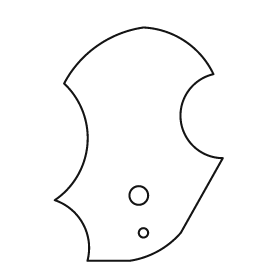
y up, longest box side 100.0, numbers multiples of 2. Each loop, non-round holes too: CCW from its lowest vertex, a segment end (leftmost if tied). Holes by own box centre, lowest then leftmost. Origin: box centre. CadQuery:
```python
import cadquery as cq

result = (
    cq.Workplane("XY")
    .moveTo(-22.0, -50.0)
    .lineTo(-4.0, -50.0)
    .threePointArc((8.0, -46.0), (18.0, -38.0))
    .lineTo(36.0, -6.0)
    .threePointArc((18.0, 10.0), (32.0, 30.0))
    .threePointArc((20.0, 44.0), (2.0, 50.0))
    .threePointArc((-18.0, 42.0), (-32.0, 26.0))
    .threePointArc((-22.0, 0.0), (-36.0, -24.0))
    .threePointArc((-24.0, -34.0), (-22.0, -50.0))
    .close()
    .moveTo(2.0, -38.0)
    .circle(2.0)
    .moveTo(0.0, -22.0)
    .circle(4.0)
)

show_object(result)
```